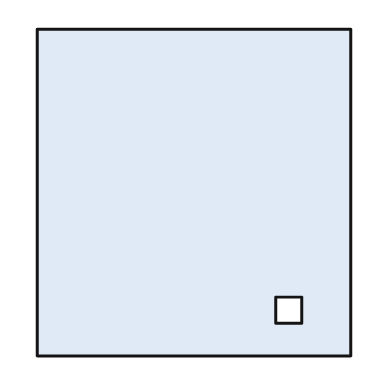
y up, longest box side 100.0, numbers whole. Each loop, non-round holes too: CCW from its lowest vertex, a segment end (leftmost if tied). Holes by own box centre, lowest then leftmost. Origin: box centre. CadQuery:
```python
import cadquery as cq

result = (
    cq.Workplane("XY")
    .moveTo(-48.0, -50.0)
    .lineTo(48.0, -50.0)
    .lineTo(48.0, 50.0)
    .lineTo(-48.0, 50.0)
    .close()
    .moveTo(25.0, -40.0)
    .lineTo(33.0, -40.0)
    .lineTo(33.0, -32.0)
    .lineTo(25.0, -32.0)
    .close()
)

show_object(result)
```